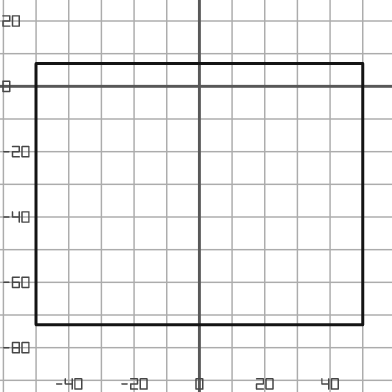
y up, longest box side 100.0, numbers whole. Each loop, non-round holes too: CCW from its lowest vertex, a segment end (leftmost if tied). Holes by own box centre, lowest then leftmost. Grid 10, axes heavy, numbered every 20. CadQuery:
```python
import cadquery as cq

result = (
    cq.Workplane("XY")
    .moveTo(-50.0, -73.0)
    .lineTo(50.0, -73.0)
    .lineTo(50.0, 7.0)
    .lineTo(-50.0, 7.0)
    .close()
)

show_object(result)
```